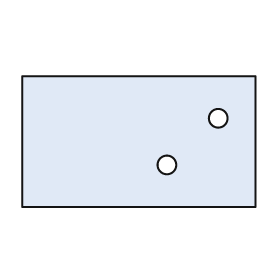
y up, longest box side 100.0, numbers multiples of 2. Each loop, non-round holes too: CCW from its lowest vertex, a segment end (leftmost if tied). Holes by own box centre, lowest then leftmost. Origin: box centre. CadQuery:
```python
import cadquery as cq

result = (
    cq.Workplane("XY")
    .moveTo(-50.0, -28.0)
    .lineTo(50.0, -28.0)
    .lineTo(50.0, 28.0)
    .lineTo(-50.0, 28.0)
    .close()
    .moveTo(12.0, -10.0)
    .circle(4.0)
    .moveTo(34.0, 10.0)
    .circle(4.0)
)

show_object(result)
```